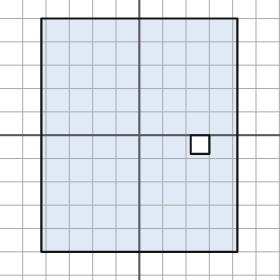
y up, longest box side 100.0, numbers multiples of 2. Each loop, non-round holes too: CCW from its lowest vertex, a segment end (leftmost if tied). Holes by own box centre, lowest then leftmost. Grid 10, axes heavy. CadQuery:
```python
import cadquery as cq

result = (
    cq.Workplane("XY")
    .moveTo(-42.0, -50.0)
    .lineTo(42.0, -50.0)
    .lineTo(42.0, 50.0)
    .lineTo(-42.0, 50.0)
    .close()
    .moveTo(22.0, -8.0)
    .lineTo(30.0, -8.0)
    .lineTo(30.0, 0.0)
    .lineTo(22.0, 0.0)
    .close()
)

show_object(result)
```